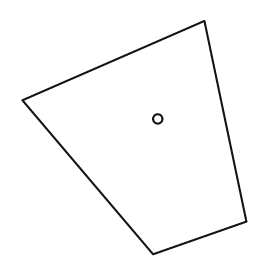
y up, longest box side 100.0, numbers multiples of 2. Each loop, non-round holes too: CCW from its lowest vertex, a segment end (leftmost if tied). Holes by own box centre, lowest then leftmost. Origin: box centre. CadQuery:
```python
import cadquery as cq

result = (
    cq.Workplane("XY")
    .moveTo(8.0, -50.0)
    .lineTo(48.0, -36.0)
    .lineTo(30.0, 50.0)
    .lineTo(-48.0, 16.0)
    .close()
    .moveTo(10.0, 8.0)
    .circle(2.0)
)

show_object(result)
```